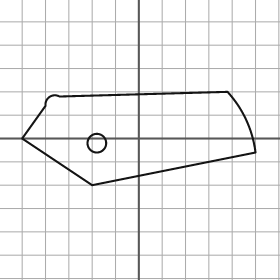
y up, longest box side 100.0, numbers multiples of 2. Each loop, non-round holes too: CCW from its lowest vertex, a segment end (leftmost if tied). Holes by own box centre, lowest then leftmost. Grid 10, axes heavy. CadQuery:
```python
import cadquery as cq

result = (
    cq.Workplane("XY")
    .moveTo(-20.0, -20.0)
    .lineTo(50.0, -6.0)
    .threePointArc((46.0, 8.0), (38.0, 20.0))
    .lineTo(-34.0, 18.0)
    .threePointArc((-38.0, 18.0), (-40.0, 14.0))
    .lineTo(-50.0, 0.0)
    .close()
    .moveTo(-18.0, -2.0)
    .circle(4.0)
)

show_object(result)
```